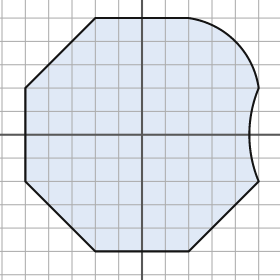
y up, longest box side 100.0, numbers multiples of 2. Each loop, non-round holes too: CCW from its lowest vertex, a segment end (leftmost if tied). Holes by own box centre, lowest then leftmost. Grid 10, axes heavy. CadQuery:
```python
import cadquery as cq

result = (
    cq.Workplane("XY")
    .moveTo(-20.0, -50.0)
    .lineTo(20.0, -50.0)
    .lineTo(50.0, -20.0)
    .threePointArc((46.0, 0.0), (50.0, 20.0))
    .threePointArc((40.0, 40.0), (20.0, 50.0))
    .lineTo(-20.0, 50.0)
    .lineTo(-50.0, 20.0)
    .lineTo(-50.0, -20.0)
    .close()
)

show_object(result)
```